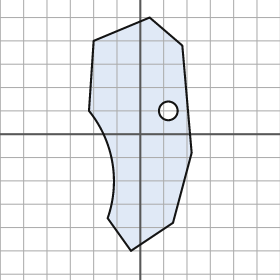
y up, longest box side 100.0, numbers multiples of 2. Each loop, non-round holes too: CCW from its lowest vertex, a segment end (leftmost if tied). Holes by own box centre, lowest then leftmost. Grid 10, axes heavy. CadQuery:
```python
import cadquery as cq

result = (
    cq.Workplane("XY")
    .moveTo(-4.0, -50.0)
    .lineTo(14.0, -38.0)
    .lineTo(22.0, -8.0)
    .lineTo(18.0, 38.0)
    .lineTo(4.0, 50.0)
    .lineTo(-20.0, 40.0)
    .lineTo(-22.0, 10.0)
    .threePointArc((-12.0, -12.0), (-14.0, -36.0))
    .close()
    .moveTo(12.0, 10.0)
    .circle(4.0)
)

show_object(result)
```